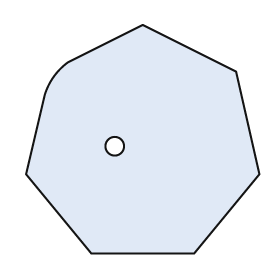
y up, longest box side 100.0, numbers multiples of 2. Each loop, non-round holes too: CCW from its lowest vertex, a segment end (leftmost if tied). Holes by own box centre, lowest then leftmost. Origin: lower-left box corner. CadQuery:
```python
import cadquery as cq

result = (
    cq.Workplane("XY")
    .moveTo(28.0, 0.0)
    .lineTo(72.0, 0.0)
    .lineTo(100.0, 34.0)
    .lineTo(90.0, 78.0)
    .lineTo(50.0, 98.0)
    .lineTo(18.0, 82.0)
    .threePointArc((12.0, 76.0), (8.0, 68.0))
    .lineTo(0.0, 34.0)
    .close()
    .moveTo(38.0, 46.0)
    .circle(4.0)
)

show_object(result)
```